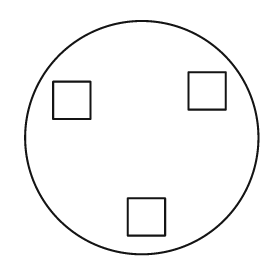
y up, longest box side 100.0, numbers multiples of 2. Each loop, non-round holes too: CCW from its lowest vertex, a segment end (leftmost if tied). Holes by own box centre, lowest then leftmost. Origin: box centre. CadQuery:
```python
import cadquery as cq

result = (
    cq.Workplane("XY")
    .moveTo(0.0, 0.0)
    .circle(50.0)
    .moveTo(-6.0, -42.0)
    .lineTo(10.0, -42.0)
    .lineTo(10.0, -26.0)
    .lineTo(-6.0, -26.0)
    .close()
    .moveTo(-38.0, 8.0)
    .lineTo(-22.0, 8.0)
    .lineTo(-22.0, 24.0)
    .lineTo(-38.0, 24.0)
    .close()
    .moveTo(20.0, 12.0)
    .lineTo(36.0, 12.0)
    .lineTo(36.0, 28.0)
    .lineTo(20.0, 28.0)
    .close()
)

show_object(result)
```